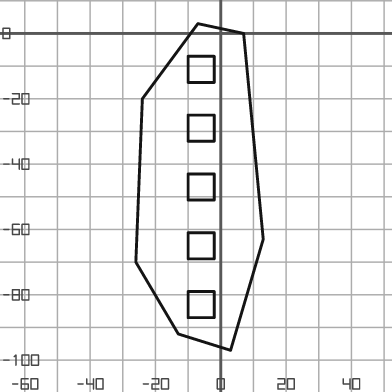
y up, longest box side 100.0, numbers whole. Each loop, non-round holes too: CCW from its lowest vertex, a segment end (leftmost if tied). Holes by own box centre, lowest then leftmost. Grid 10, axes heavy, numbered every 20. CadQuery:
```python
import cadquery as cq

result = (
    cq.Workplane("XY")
    .moveTo(3.0, -97.0)
    .lineTo(13.0, -63.0)
    .lineTo(7.0, 0.0)
    .lineTo(-7.0, 3.0)
    .lineTo(-24.0, -20.0)
    .lineTo(-26.0, -70.0)
    .lineTo(-13.0, -92.0)
    .close()
    .moveTo(-10.0, -87.0)
    .lineTo(-2.0, -87.0)
    .lineTo(-2.0, -79.0)
    .lineTo(-10.0, -79.0)
    .close()
    .moveTo(-10.0, -69.0)
    .lineTo(-2.0, -69.0)
    .lineTo(-2.0, -61.0)
    .lineTo(-10.0, -61.0)
    .close()
    .moveTo(-10.0, -51.0)
    .lineTo(-2.0, -51.0)
    .lineTo(-2.0, -43.0)
    .lineTo(-10.0, -43.0)
    .close()
    .moveTo(-10.0, -33.0)
    .lineTo(-2.0, -33.0)
    .lineTo(-2.0, -25.0)
    .lineTo(-10.0, -25.0)
    .close()
    .moveTo(-10.0, -15.0)
    .lineTo(-2.0, -15.0)
    .lineTo(-2.0, -7.0)
    .lineTo(-10.0, -7.0)
    .close()
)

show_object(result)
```